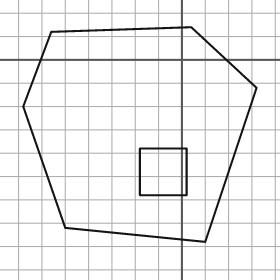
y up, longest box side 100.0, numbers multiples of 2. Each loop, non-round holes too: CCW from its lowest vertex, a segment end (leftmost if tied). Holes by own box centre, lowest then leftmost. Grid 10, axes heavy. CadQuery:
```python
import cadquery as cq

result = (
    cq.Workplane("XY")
    .moveTo(10.0, -78.0)
    .lineTo(32.0, -12.0)
    .lineTo(4.0, 14.0)
    .lineTo(-56.0, 12.0)
    .lineTo(-68.0, -20.0)
    .lineTo(-50.0, -72.0)
    .close()
    .moveTo(-18.0, -58.0)
    .lineTo(2.0, -58.0)
    .lineTo(2.0, -38.0)
    .lineTo(-18.0, -38.0)
    .close()
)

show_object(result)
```